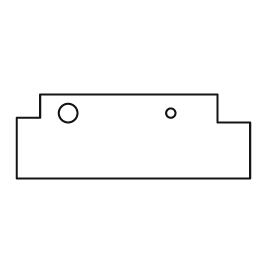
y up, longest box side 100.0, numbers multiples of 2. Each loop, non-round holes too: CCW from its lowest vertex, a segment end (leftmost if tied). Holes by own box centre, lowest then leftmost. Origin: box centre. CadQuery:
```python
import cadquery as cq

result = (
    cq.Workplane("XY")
    .moveTo(-50.0, -18.0)
    .lineTo(50.0, -18.0)
    .lineTo(50.0, 6.0)
    .lineTo(36.0, 6.0)
    .lineTo(36.0, 18.0)
    .lineTo(-40.0, 18.0)
    .lineTo(-40.0, 8.0)
    .lineTo(-50.0, 8.0)
    .close()
    .moveTo(-28.0, 10.0)
    .circle(4.0)
    .moveTo(16.0, 10.0)
    .circle(2.0)
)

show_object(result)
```